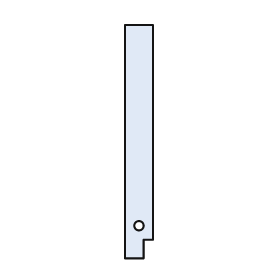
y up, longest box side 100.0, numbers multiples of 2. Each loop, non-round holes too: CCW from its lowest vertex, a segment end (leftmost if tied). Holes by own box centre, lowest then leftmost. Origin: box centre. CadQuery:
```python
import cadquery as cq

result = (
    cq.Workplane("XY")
    .moveTo(-6.0, -50.0)
    .lineTo(2.0, -50.0)
    .lineTo(2.0, -42.0)
    .lineTo(6.0, -42.0)
    .lineTo(6.0, 50.0)
    .lineTo(-6.0, 50.0)
    .close()
    .moveTo(0.0, -36.0)
    .circle(2.0)
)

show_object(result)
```